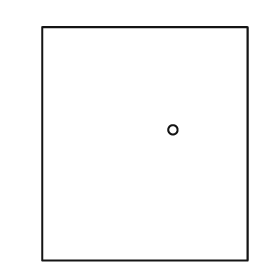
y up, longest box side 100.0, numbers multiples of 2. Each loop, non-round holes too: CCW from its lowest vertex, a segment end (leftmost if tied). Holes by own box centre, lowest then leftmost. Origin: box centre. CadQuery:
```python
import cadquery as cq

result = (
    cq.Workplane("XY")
    .moveTo(-44.0, -50.0)
    .lineTo(44.0, -50.0)
    .lineTo(44.0, 50.0)
    .lineTo(-44.0, 50.0)
    .close()
    .moveTo(12.0, 6.0)
    .circle(2.0)
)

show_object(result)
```